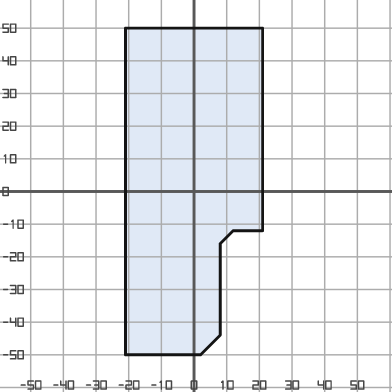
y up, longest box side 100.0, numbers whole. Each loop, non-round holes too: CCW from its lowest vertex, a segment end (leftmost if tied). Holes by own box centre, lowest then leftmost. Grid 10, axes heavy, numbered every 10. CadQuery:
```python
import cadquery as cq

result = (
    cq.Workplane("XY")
    .moveTo(-21.0, -50.0)
    .lineTo(2.0, -50.0)
    .lineTo(8.0, -44.0)
    .lineTo(8.0, -16.0)
    .lineTo(12.0, -12.0)
    .lineTo(21.0, -12.0)
    .lineTo(21.0, 50.0)
    .lineTo(-21.0, 50.0)
    .close()
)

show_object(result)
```